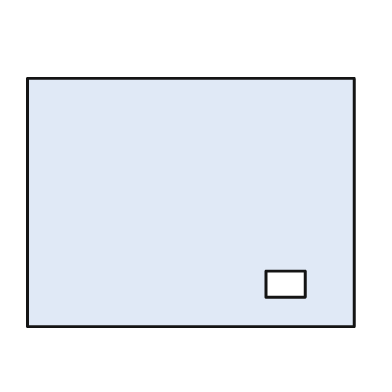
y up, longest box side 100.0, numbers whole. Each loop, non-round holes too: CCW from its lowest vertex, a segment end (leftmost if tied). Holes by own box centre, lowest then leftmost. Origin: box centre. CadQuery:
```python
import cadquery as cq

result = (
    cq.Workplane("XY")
    .moveTo(-50.0, -38.0)
    .lineTo(50.0, -38.0)
    .lineTo(50.0, 38.0)
    .lineTo(-50.0, 38.0)
    .close()
    .moveTo(23.0, -29.0)
    .lineTo(35.0, -29.0)
    .lineTo(35.0, -21.0)
    .lineTo(23.0, -21.0)
    .close()
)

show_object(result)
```